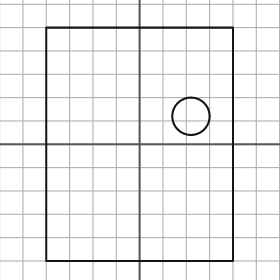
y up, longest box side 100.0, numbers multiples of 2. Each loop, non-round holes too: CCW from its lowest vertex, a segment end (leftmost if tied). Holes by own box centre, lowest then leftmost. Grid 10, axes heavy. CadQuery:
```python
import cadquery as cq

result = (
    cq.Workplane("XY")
    .moveTo(-40.0, -50.0)
    .lineTo(40.0, -50.0)
    .lineTo(40.0, 50.0)
    .lineTo(-40.0, 50.0)
    .close()
    .moveTo(22.0, 12.0)
    .circle(8.0)
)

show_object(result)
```